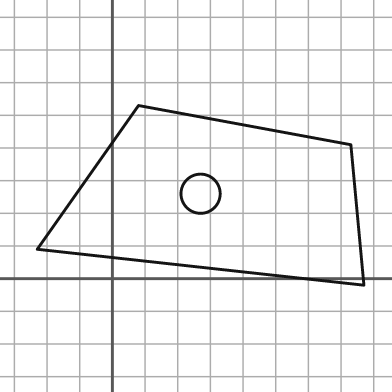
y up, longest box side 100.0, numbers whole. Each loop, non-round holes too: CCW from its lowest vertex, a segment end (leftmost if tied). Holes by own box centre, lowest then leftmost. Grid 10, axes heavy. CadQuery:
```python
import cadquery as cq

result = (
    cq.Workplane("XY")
    .moveTo(77.0, -2.0)
    .lineTo(73.0, 41.0)
    .lineTo(8.0, 53.0)
    .lineTo(-23.0, 9.0)
    .close()
    .moveTo(27.0, 26.0)
    .circle(6.0)
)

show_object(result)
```